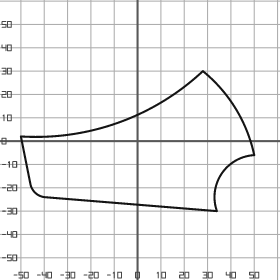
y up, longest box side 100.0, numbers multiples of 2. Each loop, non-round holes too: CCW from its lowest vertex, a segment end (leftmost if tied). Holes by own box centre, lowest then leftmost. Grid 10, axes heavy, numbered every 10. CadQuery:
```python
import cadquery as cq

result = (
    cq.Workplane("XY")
    .moveTo(34.0, -30.0)
    .threePointArc((36.0, -14.0), (50.0, -6.0))
    .threePointArc((42.0, 14.0), (28.0, 30.0))
    .threePointArc((-8.0, 8.0), (-50.0, 2.0))
    .lineTo(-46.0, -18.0)
    .threePointArc((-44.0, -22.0), (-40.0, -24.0))
    .close()
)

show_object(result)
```